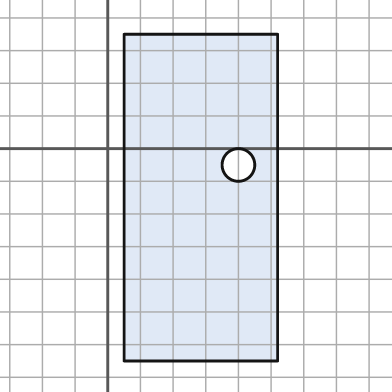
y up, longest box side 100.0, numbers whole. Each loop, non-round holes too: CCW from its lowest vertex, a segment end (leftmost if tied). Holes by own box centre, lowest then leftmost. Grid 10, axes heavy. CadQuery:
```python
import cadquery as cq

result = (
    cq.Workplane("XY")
    .moveTo(5.0, -65.0)
    .lineTo(52.0, -65.0)
    .lineTo(52.0, 35.0)
    .lineTo(5.0, 35.0)
    .close()
    .moveTo(40.0, -5.0)
    .circle(5.0)
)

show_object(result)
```